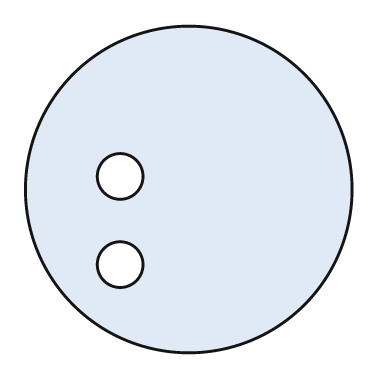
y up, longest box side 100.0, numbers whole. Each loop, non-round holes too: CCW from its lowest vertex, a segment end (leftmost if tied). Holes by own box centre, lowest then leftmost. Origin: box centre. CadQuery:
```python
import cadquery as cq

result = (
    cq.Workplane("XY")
    .moveTo(0.0, 0.0)
    .circle(50.0)
    .moveTo(-21.0, -23.0)
    .circle(7.0)
    .moveTo(-21.0, 4.0)
    .circle(7.0)
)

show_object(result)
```